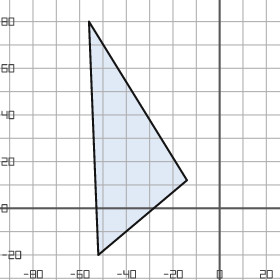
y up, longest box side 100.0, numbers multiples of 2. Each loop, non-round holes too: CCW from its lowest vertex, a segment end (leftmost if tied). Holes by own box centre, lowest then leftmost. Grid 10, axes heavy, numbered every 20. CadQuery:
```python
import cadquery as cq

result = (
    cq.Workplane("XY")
    .moveTo(-52.0, -20.0)
    .lineTo(-14.0, 12.0)
    .lineTo(-56.0, 80.0)
    .close()
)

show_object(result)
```